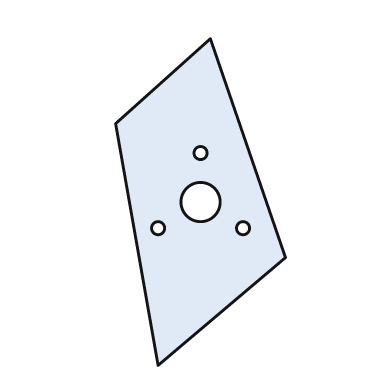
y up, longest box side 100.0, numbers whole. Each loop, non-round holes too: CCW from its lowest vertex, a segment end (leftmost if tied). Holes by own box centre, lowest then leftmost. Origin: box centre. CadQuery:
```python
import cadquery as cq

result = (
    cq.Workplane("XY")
    .moveTo(-13.0, -50.0)
    .lineTo(26.0, -17.0)
    .lineTo(3.0, 50.0)
    .lineTo(-26.0, 24.0)
    .close()
    .moveTo(-13.0, -8.0)
    .circle(2.0)
    .moveTo(13.0, -8.0)
    .circle(2.0)
    .moveTo(0.0, 0.0)
    .circle(6.0)
    .moveTo(0.0, 15.0)
    .circle(2.0)
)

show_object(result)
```